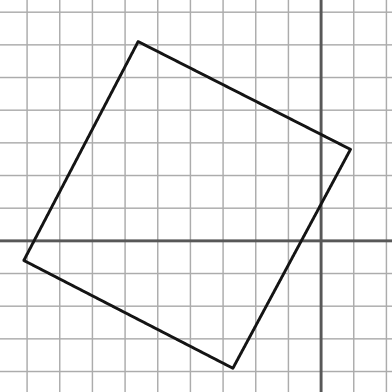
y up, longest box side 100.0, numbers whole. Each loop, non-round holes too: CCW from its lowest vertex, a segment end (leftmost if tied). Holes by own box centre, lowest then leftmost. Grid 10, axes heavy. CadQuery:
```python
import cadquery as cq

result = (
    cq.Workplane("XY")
    .moveTo(-27.0, -39.0)
    .lineTo(9.0, 28.0)
    .lineTo(-56.0, 61.0)
    .lineTo(-91.0, -6.0)
    .close()
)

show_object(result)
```